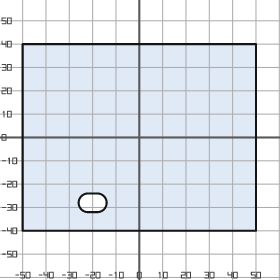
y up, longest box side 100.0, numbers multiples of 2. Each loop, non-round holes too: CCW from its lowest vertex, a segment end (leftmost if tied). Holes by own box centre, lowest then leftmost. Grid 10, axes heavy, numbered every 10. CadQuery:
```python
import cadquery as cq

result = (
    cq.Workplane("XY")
    .moveTo(-50.0, -40.0)
    .lineTo(50.0, -40.0)
    .lineTo(50.0, 40.0)
    .lineTo(-50.0, 40.0)
    .close()
    .moveTo(-22.0, -32.0)
    .lineTo(-18.0, -32.0)
    .threePointArc((-14.0, -28.0), (-18.0, -24.0))
    .lineTo(-22.0, -24.0)
    .threePointArc((-26.0, -28.0), (-22.0, -32.0))
    .close()
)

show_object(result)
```